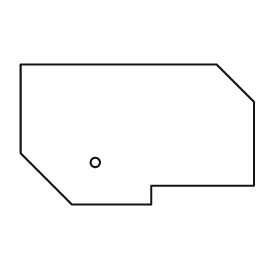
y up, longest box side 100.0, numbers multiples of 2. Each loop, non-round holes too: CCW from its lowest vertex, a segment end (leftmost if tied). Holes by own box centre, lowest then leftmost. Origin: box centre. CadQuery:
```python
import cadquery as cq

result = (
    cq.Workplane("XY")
    .moveTo(-28.0, -30.0)
    .lineTo(6.0, -30.0)
    .lineTo(6.0, -22.0)
    .lineTo(50.0, -22.0)
    .lineTo(50.0, 14.0)
    .lineTo(34.0, 30.0)
    .lineTo(-50.0, 30.0)
    .lineTo(-50.0, -8.0)
    .close()
    .moveTo(-18.0, -12.0)
    .circle(2.0)
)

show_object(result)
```